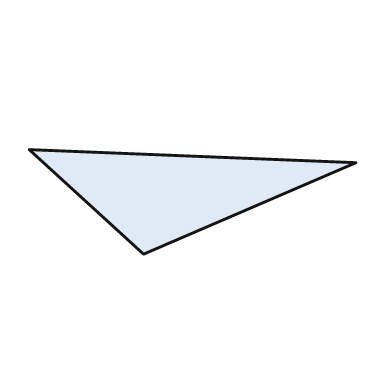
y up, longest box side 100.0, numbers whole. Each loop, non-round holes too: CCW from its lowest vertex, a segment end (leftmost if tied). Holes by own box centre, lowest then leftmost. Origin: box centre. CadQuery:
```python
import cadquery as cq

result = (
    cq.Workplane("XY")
    .moveTo(-15.0, -16.0)
    .lineTo(50.0, 12.0)
    .lineTo(-50.0, 16.0)
    .close()
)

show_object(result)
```